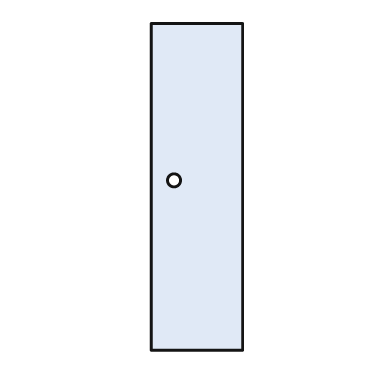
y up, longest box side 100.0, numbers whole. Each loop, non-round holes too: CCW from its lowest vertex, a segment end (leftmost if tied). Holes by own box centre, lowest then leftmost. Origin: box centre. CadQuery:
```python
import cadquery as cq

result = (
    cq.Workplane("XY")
    .moveTo(-14.0, -50.0)
    .lineTo(14.0, -50.0)
    .lineTo(14.0, 50.0)
    .lineTo(-14.0, 50.0)
    .close()
    .moveTo(-7.0, 2.0)
    .circle(2.0)
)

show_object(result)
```